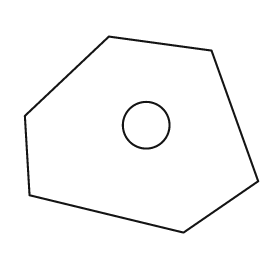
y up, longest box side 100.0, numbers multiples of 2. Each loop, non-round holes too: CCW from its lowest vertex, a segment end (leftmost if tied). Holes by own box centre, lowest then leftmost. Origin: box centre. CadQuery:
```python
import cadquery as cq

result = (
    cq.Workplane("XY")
    .moveTo(18.0, -42.0)
    .lineTo(50.0, -20.0)
    .lineTo(30.0, 36.0)
    .lineTo(-14.0, 42.0)
    .lineTo(-50.0, 8.0)
    .lineTo(-48.0, -26.0)
    .close()
    .moveTo(2.0, 4.0)
    .circle(10.0)
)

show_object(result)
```